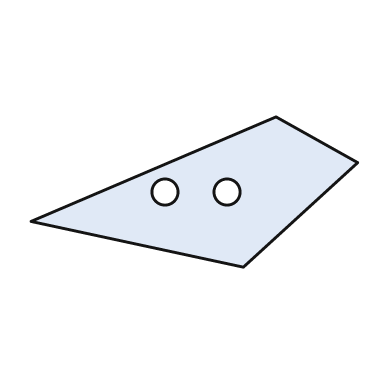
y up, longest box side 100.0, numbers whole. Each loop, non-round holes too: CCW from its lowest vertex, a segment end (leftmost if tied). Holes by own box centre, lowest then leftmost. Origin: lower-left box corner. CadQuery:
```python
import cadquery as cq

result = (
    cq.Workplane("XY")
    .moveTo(65.0, 0.0)
    .lineTo(100.0, 32.0)
    .lineTo(75.0, 46.0)
    .lineTo(0.0, 14.0)
    .close()
    .moveTo(41.0, 23.0)
    .circle(4.0)
    .moveTo(60.0, 23.0)
    .circle(4.0)
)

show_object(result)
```